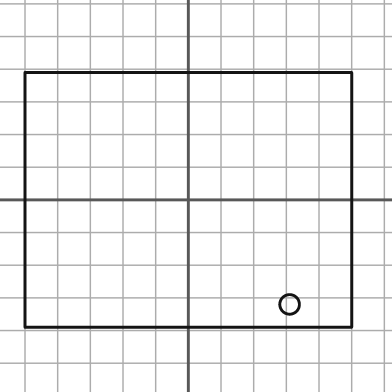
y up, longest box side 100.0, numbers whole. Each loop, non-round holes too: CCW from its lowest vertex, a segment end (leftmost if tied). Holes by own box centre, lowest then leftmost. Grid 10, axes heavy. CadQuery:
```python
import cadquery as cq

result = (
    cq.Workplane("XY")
    .moveTo(-50.0, -39.0)
    .lineTo(50.0, -39.0)
    .lineTo(50.0, 39.0)
    .lineTo(-50.0, 39.0)
    .close()
    .moveTo(31.0, -32.0)
    .circle(3.0)
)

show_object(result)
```